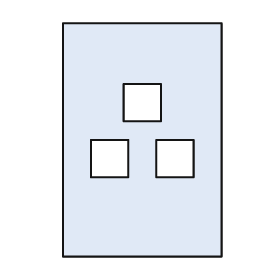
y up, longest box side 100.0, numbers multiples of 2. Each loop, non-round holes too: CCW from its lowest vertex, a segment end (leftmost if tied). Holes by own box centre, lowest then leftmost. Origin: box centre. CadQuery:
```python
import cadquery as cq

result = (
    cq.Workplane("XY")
    .moveTo(-34.0, -50.0)
    .lineTo(34.0, -50.0)
    .lineTo(34.0, 50.0)
    .lineTo(-34.0, 50.0)
    .close()
    .moveTo(-22.0, -16.0)
    .lineTo(-6.0, -16.0)
    .lineTo(-6.0, 0.0)
    .lineTo(-22.0, 0.0)
    .close()
    .moveTo(6.0, -16.0)
    .lineTo(22.0, -16.0)
    .lineTo(22.0, 0.0)
    .lineTo(6.0, 0.0)
    .close()
    .moveTo(-8.0, 8.0)
    .lineTo(8.0, 8.0)
    .lineTo(8.0, 24.0)
    .lineTo(-8.0, 24.0)
    .close()
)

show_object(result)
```